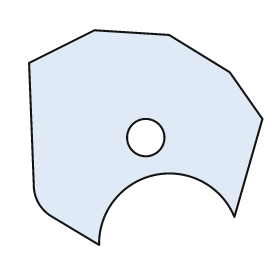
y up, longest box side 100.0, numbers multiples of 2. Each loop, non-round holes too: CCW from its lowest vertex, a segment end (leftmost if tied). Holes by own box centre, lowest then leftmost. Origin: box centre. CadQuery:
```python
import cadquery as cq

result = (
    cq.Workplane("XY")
    .moveTo(-20.0, -46.0)
    .threePointArc((4.0, -16.0), (38.0, -34.0))
    .lineTo(50.0, 8.0)
    .lineTo(36.0, 28.0)
    .lineTo(10.0, 44.0)
    .lineTo(-22.0, 46.0)
    .lineTo(-50.0, 32.0)
    .lineTo(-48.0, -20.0)
    .threePointArc((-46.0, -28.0), (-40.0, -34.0))
    .close()
    .moveTo(0.0, 0.0)
    .circle(8.0)
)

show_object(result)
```